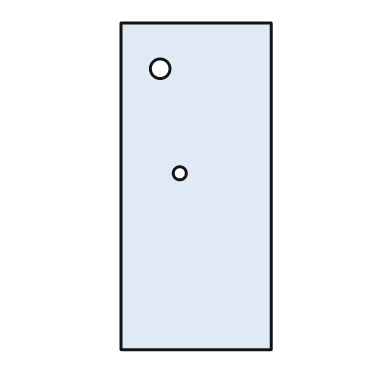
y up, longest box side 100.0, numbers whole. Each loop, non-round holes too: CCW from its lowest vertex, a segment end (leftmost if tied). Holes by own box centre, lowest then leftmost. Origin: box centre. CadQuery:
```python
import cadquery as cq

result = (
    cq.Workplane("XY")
    .moveTo(-23.0, -50.0)
    .lineTo(23.0, -50.0)
    .lineTo(23.0, 50.0)
    .lineTo(-23.0, 50.0)
    .close()
    .moveTo(-5.0, 4.0)
    .circle(2.0)
    .moveTo(-11.0, 36.0)
    .circle(3.0)
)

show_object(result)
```